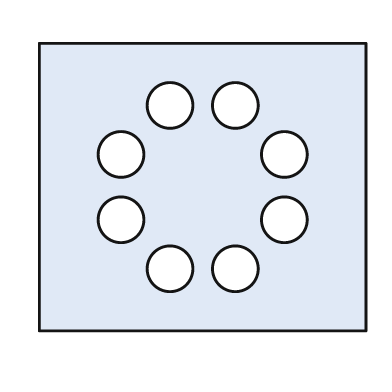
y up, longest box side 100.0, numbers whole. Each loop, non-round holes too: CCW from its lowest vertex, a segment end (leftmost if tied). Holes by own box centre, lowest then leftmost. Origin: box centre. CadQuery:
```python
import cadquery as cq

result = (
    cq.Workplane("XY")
    .moveTo(-50.0, -44.0)
    .lineTo(50.0, -44.0)
    .lineTo(50.0, 44.0)
    .lineTo(-50.0, 44.0)
    .close()
    .moveTo(-10.0, -25.0)
    .circle(7.0)
    .moveTo(10.0, -25.0)
    .circle(7.0)
    .moveTo(-25.0, -10.0)
    .circle(7.0)
    .moveTo(25.0, -10.0)
    .circle(7.0)
    .moveTo(-25.0, 10.0)
    .circle(7.0)
    .moveTo(25.0, 10.0)
    .circle(7.0)
    .moveTo(-10.0, 25.0)
    .circle(7.0)
    .moveTo(10.0, 25.0)
    .circle(7.0)
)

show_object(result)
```